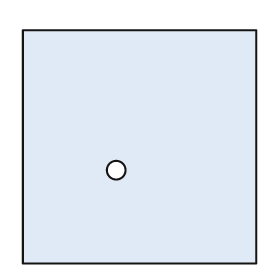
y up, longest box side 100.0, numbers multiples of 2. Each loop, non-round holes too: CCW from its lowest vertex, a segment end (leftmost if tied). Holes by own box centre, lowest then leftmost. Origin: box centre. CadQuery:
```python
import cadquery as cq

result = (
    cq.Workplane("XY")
    .moveTo(-50.0, -50.0)
    .lineTo(50.0, -50.0)
    .lineTo(50.0, 50.0)
    .lineTo(-50.0, 50.0)
    .close()
    .moveTo(-10.0, -10.0)
    .circle(4.0)
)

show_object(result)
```